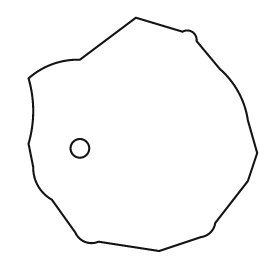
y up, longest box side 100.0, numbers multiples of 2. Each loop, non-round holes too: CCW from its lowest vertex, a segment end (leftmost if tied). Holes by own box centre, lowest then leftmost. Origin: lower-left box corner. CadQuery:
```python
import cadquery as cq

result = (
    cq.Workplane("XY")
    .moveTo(56.0, 0.0)
    .lineTo(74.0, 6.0)
    .threePointArc((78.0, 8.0), (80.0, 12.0))
    .lineTo(94.0, 30.0)
    .lineTo(98.0, 42.0)
    .lineTo(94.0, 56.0)
    .threePointArc((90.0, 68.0), (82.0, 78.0))
    .lineTo(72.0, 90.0)
    .threePointArc((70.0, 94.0), (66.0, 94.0))
    .lineTo(46.0, 100.0)
    .lineTo(22.0, 82.0)
    .threePointArc((10.0, 80.0), (0.0, 74.0))
    .threePointArc((2.0, 60.0), (0.0, 46.0))
    .lineTo(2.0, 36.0)
    .threePointArc((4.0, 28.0), (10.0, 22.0))
    .lineTo(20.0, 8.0)
    .threePointArc((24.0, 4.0), (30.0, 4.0))
    .close()
    .moveTo(22.0, 44.0)
    .circle(4.0)
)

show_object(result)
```